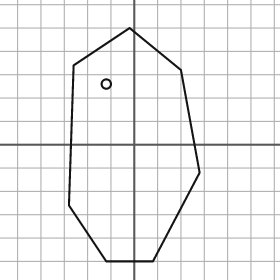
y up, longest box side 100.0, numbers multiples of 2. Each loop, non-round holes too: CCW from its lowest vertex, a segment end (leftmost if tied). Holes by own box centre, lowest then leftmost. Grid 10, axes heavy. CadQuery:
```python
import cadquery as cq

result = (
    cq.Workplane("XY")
    .moveTo(-12.0, -50.0)
    .lineTo(8.0, -50.0)
    .lineTo(28.0, -12.0)
    .lineTo(20.0, 32.0)
    .lineTo(-2.0, 50.0)
    .lineTo(-26.0, 34.0)
    .lineTo(-28.0, -26.0)
    .close()
    .moveTo(-12.0, 26.0)
    .circle(2.0)
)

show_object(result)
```